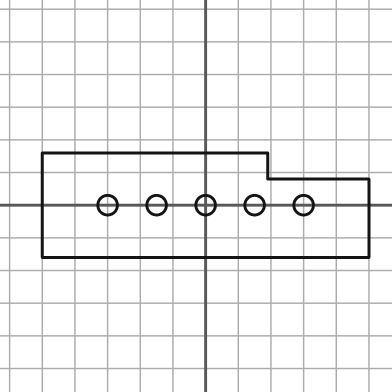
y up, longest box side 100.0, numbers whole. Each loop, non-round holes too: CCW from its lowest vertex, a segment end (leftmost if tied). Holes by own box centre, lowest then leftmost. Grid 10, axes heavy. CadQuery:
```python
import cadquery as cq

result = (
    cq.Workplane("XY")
    .moveTo(-50.0, -16.0)
    .lineTo(50.0, -16.0)
    .lineTo(50.0, 8.0)
    .lineTo(19.0, 8.0)
    .lineTo(19.0, 16.0)
    .lineTo(-50.0, 16.0)
    .close()
    .moveTo(-30.0, 0.0)
    .circle(3.0)
    .moveTo(-15.0, 0.0)
    .circle(3.0)
    .moveTo(0.0, 0.0)
    .circle(3.0)
    .moveTo(15.0, 0.0)
    .circle(3.0)
    .moveTo(30.0, 0.0)
    .circle(3.0)
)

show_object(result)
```